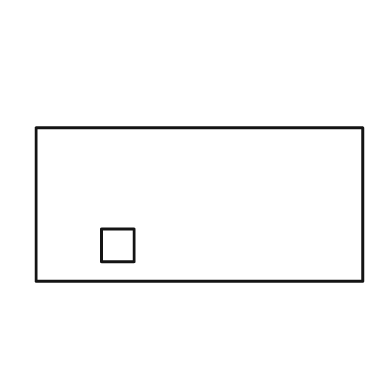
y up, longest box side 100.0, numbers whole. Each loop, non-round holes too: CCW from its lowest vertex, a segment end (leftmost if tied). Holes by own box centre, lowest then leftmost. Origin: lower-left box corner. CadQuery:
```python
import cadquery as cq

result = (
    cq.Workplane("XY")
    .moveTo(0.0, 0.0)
    .lineTo(100.0, 0.0)
    .lineTo(100.0, 47.0)
    .lineTo(0.0, 47.0)
    .close()
    .moveTo(20.0, 6.0)
    .lineTo(30.0, 6.0)
    .lineTo(30.0, 16.0)
    .lineTo(20.0, 16.0)
    .close()
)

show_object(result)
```